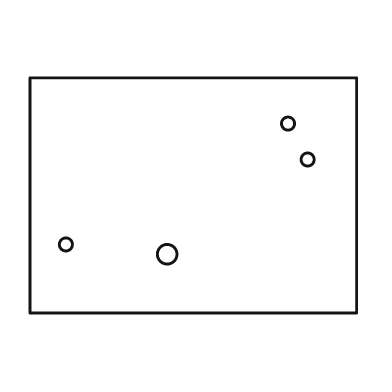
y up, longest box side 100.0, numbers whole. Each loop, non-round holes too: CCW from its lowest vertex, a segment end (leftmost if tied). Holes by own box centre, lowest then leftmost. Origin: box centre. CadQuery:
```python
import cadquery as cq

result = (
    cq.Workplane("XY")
    .moveTo(-50.0, -36.0)
    .lineTo(50.0, -36.0)
    .lineTo(50.0, 36.0)
    .lineTo(-50.0, 36.0)
    .close()
    .moveTo(-8.0, -18.0)
    .circle(3.0)
    .moveTo(-39.0, -15.0)
    .circle(2.0)
    .moveTo(35.0, 11.0)
    .circle(2.0)
    .moveTo(29.0, 22.0)
    .circle(2.0)
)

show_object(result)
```